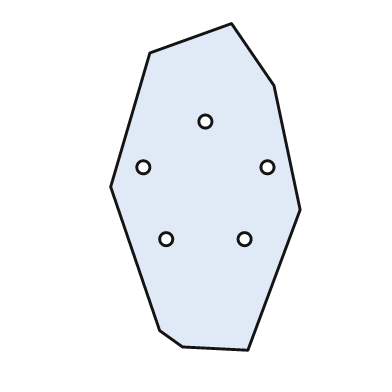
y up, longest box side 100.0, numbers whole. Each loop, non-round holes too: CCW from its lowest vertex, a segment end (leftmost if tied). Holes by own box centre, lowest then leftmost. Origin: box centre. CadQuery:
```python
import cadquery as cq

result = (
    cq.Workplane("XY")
    .moveTo(13.0, -50.0)
    .lineTo(29.0, -7.0)
    .lineTo(21.0, 31.0)
    .lineTo(8.0, 50.0)
    .lineTo(-17.0, 41.0)
    .lineTo(-29.0, 0.0)
    .lineTo(-14.0, -44.0)
    .lineTo(-7.0, -49.0)
    .close()
    .moveTo(-12.0, -16.0)
    .circle(2.0)
    .moveTo(12.0, -16.0)
    .circle(2.0)
    .moveTo(-19.0, 6.0)
    .circle(2.0)
    .moveTo(19.0, 6.0)
    .circle(2.0)
    .moveTo(0.0, 20.0)
    .circle(2.0)
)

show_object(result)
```